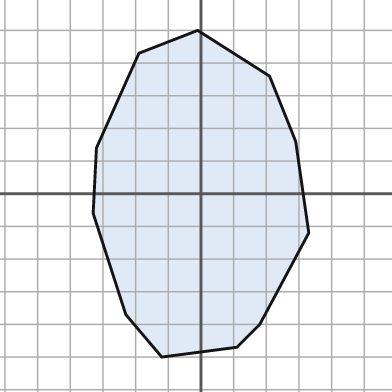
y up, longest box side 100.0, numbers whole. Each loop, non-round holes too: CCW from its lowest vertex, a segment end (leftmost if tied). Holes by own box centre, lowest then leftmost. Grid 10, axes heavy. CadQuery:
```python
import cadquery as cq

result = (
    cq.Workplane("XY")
    .moveTo(-12.0, -50.0)
    .lineTo(11.0, -47.0)
    .lineTo(18.0, -40.0)
    .lineTo(33.0, -12.0)
    .lineTo(29.0, 16.0)
    .lineTo(21.0, 36.0)
    .lineTo(-1.0, 50.0)
    .lineTo(-19.0, 43.0)
    .lineTo(-32.0, 14.0)
    .lineTo(-33.0, -6.0)
    .lineTo(-23.0, -37.0)
    .close()
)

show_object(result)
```